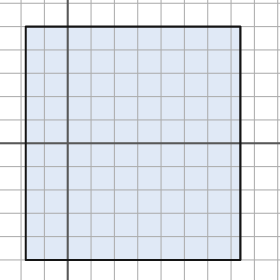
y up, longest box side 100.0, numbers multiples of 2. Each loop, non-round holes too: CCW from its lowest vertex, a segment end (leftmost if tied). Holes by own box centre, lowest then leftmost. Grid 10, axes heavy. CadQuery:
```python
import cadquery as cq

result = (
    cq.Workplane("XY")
    .moveTo(-18.0, -50.0)
    .lineTo(74.0, -50.0)
    .lineTo(74.0, 50.0)
    .lineTo(-18.0, 50.0)
    .close()
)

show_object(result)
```